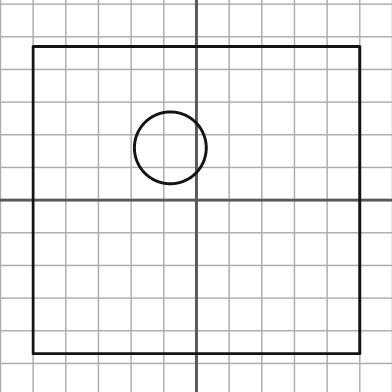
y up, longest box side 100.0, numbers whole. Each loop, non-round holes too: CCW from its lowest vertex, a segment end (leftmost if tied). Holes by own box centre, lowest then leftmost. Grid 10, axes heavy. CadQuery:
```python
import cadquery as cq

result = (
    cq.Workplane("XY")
    .moveTo(-50.0, -47.0)
    .lineTo(50.0, -47.0)
    .lineTo(50.0, 47.0)
    .lineTo(-50.0, 47.0)
    .close()
    .moveTo(-8.0, 16.0)
    .circle(11.0)
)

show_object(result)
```